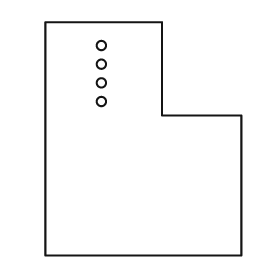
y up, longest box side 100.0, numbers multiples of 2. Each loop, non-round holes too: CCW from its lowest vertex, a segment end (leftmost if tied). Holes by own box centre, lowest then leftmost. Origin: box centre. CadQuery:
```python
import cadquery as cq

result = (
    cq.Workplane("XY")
    .moveTo(-42.0, -50.0)
    .lineTo(42.0, -50.0)
    .lineTo(42.0, 10.0)
    .lineTo(8.0, 10.0)
    .lineTo(8.0, 50.0)
    .lineTo(-42.0, 50.0)
    .close()
    .moveTo(-18.0, 16.0)
    .circle(2.0)
    .moveTo(-18.0, 24.0)
    .circle(2.0)
    .moveTo(-18.0, 32.0)
    .circle(2.0)
    .moveTo(-18.0, 40.0)
    .circle(2.0)
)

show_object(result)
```